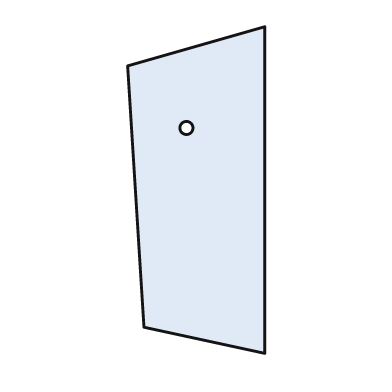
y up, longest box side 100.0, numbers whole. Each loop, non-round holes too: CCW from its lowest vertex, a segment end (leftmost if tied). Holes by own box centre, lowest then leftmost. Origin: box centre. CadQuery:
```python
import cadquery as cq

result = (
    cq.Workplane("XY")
    .moveTo(21.0, -50.0)
    .lineTo(21.0, 50.0)
    .lineTo(-21.0, 38.0)
    .lineTo(-16.0, -42.0)
    .close()
    .moveTo(-3.0, 19.0)
    .circle(2.0)
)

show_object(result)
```